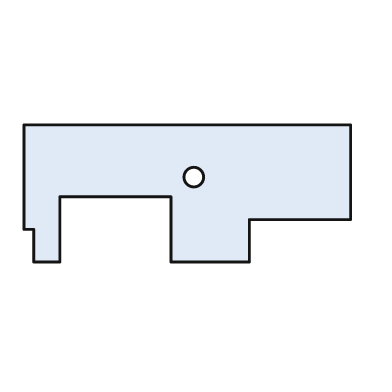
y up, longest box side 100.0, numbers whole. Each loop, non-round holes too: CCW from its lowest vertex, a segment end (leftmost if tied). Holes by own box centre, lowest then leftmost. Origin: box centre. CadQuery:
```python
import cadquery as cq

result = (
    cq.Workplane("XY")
    .moveTo(-47.0, -21.0)
    .lineTo(-39.0, -21.0)
    .lineTo(-39.0, -1.0)
    .lineTo(-5.0, -1.0)
    .lineTo(-5.0, -21.0)
    .lineTo(19.0, -21.0)
    .lineTo(19.0, -8.0)
    .lineTo(50.0, -8.0)
    .lineTo(50.0, 21.0)
    .lineTo(-50.0, 21.0)
    .lineTo(-50.0, -11.0)
    .lineTo(-47.0, -11.0)
    .close()
    .moveTo(2.0, 5.0)
    .circle(3.0)
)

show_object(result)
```